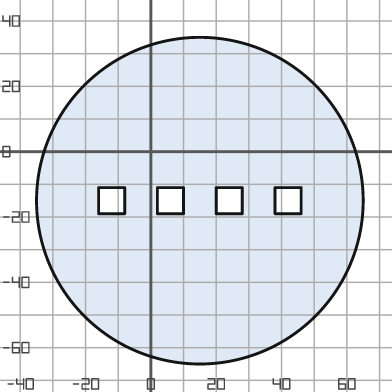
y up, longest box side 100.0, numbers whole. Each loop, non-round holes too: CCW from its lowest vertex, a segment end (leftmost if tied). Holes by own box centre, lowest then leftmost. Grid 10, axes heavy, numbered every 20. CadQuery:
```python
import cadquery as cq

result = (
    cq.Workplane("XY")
    .moveTo(15.0, -15.0)
    .circle(50.0)
    .moveTo(-16.0, -19.0)
    .lineTo(-8.0, -19.0)
    .lineTo(-8.0, -11.0)
    .lineTo(-16.0, -11.0)
    .close()
    .moveTo(2.0, -19.0)
    .lineTo(10.0, -19.0)
    .lineTo(10.0, -11.0)
    .lineTo(2.0, -11.0)
    .close()
    .moveTo(20.0, -19.0)
    .lineTo(28.0, -19.0)
    .lineTo(28.0, -11.0)
    .lineTo(20.0, -11.0)
    .close()
    .moveTo(38.0, -19.0)
    .lineTo(46.0, -19.0)
    .lineTo(46.0, -11.0)
    .lineTo(38.0, -11.0)
    .close()
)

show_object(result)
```